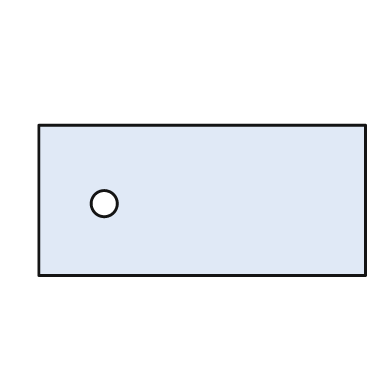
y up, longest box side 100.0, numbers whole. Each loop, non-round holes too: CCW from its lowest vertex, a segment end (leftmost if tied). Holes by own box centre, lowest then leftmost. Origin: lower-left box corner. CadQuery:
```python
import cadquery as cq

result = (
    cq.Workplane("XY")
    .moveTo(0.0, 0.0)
    .lineTo(100.0, 0.0)
    .lineTo(100.0, 46.0)
    .lineTo(0.0, 46.0)
    .close()
    .moveTo(20.0, 22.0)
    .circle(4.0)
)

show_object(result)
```